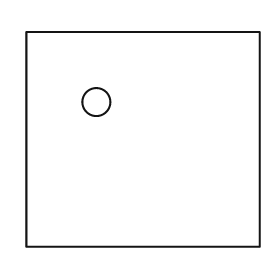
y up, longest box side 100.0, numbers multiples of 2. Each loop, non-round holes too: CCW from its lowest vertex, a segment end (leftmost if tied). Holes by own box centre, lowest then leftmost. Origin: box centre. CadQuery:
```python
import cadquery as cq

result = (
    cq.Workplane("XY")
    .moveTo(-50.0, -46.0)
    .lineTo(50.0, -46.0)
    .lineTo(50.0, 46.0)
    .lineTo(-50.0, 46.0)
    .close()
    .moveTo(-20.0, 16.0)
    .circle(6.0)
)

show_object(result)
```